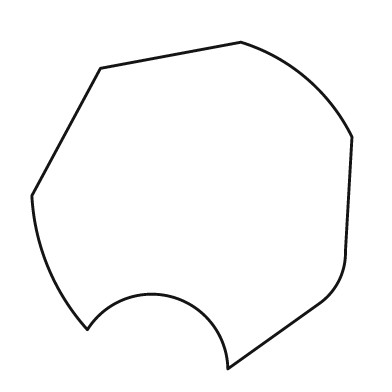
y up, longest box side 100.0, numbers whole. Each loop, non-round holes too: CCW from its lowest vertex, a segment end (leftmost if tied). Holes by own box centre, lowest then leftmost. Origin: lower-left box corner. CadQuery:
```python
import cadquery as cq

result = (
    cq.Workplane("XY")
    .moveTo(60.0, 0.0)
    .lineTo(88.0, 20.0)
    .threePointArc((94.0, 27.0), (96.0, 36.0))
    .lineTo(98.0, 71.0)
    .threePointArc((84.0, 89.0), (64.0, 100.0))
    .lineTo(21.0, 92.0)
    .lineTo(0.0, 53.0)
    .threePointArc((5.0, 31.0), (17.0, 12.0))
    .threePointArc((43.0, 22.0), (60.0, 0.0))
    .close()
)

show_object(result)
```